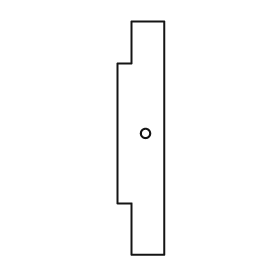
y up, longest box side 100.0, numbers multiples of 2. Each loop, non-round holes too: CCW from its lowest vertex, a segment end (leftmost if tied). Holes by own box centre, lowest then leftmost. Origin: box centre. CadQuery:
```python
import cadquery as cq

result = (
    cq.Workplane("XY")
    .moveTo(-4.0, -50.0)
    .lineTo(10.0, -50.0)
    .lineTo(10.0, 50.0)
    .lineTo(-4.0, 50.0)
    .lineTo(-4.0, 32.0)
    .lineTo(-10.0, 32.0)
    .lineTo(-10.0, -28.0)
    .lineTo(-4.0, -28.0)
    .close()
    .moveTo(2.0, 2.0)
    .circle(2.0)
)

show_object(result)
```